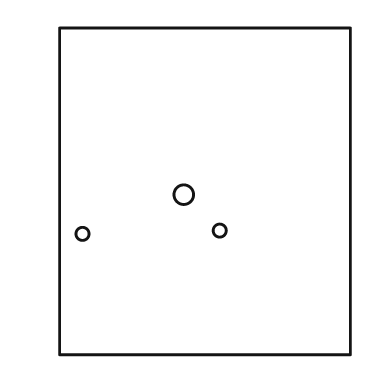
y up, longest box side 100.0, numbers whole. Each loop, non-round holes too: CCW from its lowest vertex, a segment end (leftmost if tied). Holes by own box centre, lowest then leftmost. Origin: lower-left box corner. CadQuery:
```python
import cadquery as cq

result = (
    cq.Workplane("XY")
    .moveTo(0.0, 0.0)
    .lineTo(89.0, 0.0)
    .lineTo(89.0, 100.0)
    .lineTo(0.0, 100.0)
    .close()
    .moveTo(7.0, 37.0)
    .circle(2.0)
    .moveTo(49.0, 38.0)
    .circle(2.0)
    .moveTo(38.0, 49.0)
    .circle(3.0)
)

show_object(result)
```